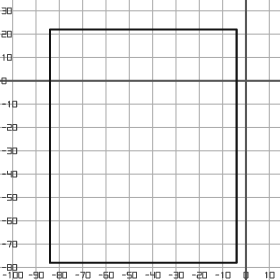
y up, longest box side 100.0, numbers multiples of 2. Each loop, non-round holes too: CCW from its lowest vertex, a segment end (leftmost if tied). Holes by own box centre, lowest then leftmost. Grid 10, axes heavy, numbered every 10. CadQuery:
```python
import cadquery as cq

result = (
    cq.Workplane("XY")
    .moveTo(-84.0, -78.0)
    .lineTo(-4.0, -78.0)
    .lineTo(-4.0, 22.0)
    .lineTo(-84.0, 22.0)
    .close()
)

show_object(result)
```